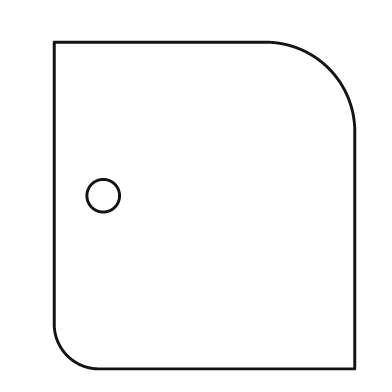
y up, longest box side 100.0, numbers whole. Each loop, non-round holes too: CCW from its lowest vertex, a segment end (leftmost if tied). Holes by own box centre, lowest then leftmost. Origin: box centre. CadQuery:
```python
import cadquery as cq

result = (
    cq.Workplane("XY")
    .moveTo(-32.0, -50.0)
    .lineTo(46.0, -50.0)
    .lineTo(46.0, 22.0)
    .threePointArc((38.0, 42.0), (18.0, 50.0))
    .lineTo(-46.0, 50.0)
    .lineTo(-46.0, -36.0)
    .threePointArc((-42.0, -46.0), (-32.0, -50.0))
    .close()
    .moveTo(-31.0, 3.0)
    .circle(5.0)
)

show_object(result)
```